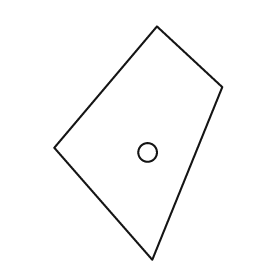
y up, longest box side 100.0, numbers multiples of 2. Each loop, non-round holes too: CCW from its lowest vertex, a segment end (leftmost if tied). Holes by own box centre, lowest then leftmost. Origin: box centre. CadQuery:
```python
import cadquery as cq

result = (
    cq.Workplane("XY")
    .moveTo(6.0, -50.0)
    .lineTo(36.0, 24.0)
    .lineTo(8.0, 50.0)
    .lineTo(-36.0, -2.0)
    .close()
    .moveTo(4.0, -4.0)
    .circle(4.0)
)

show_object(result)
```